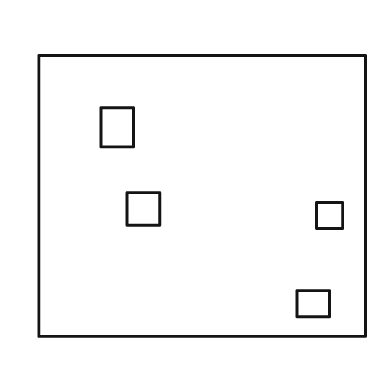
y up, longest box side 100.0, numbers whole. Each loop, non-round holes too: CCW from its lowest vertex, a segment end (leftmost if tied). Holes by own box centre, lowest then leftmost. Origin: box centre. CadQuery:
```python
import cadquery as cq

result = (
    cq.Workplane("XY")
    .moveTo(-50.0, -43.0)
    .lineTo(50.0, -43.0)
    .lineTo(50.0, 43.0)
    .lineTo(-50.0, 43.0)
    .close()
    .moveTo(29.0, -37.0)
    .lineTo(39.0, -37.0)
    .lineTo(39.0, -29.0)
    .lineTo(29.0, -29.0)
    .close()
    .moveTo(35.0, -10.0)
    .lineTo(43.0, -10.0)
    .lineTo(43.0, -2.0)
    .lineTo(35.0, -2.0)
    .close()
    .moveTo(-23.0, -9.0)
    .lineTo(-13.0, -9.0)
    .lineTo(-13.0, 1.0)
    .lineTo(-23.0, 1.0)
    .close()
    .moveTo(-31.0, 15.0)
    .lineTo(-21.0, 15.0)
    .lineTo(-21.0, 27.0)
    .lineTo(-31.0, 27.0)
    .close()
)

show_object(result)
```